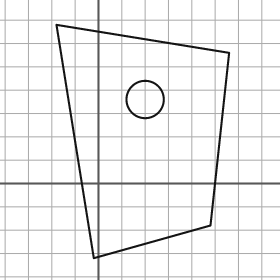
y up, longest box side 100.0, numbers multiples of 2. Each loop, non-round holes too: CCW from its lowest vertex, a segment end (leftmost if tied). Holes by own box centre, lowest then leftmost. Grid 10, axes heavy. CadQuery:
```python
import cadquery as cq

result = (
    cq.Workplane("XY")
    .moveTo(-2.0, -32.0)
    .lineTo(48.0, -18.0)
    .lineTo(56.0, 56.0)
    .lineTo(-18.0, 68.0)
    .close()
    .moveTo(20.0, 36.0)
    .circle(8.0)
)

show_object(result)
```